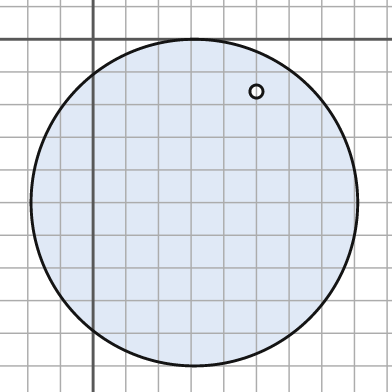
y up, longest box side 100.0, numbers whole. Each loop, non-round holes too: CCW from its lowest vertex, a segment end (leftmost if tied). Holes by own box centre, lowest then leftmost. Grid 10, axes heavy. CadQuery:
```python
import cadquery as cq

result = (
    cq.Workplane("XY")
    .moveTo(31.0, -50.0)
    .circle(50.0)
    .moveTo(50.0, -16.0)
    .circle(2.0)
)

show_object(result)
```